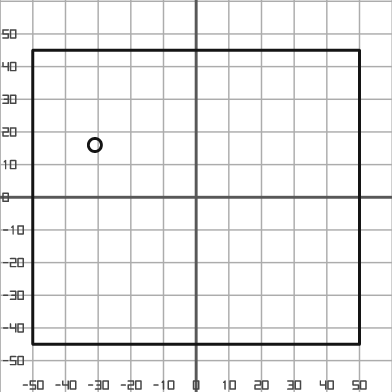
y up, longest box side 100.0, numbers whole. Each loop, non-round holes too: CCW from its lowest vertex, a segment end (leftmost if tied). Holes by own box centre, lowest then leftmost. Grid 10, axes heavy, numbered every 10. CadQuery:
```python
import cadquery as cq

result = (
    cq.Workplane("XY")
    .moveTo(-50.0, -45.0)
    .lineTo(50.0, -45.0)
    .lineTo(50.0, 45.0)
    .lineTo(-50.0, 45.0)
    .close()
    .moveTo(-31.0, 16.0)
    .circle(2.0)
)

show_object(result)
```